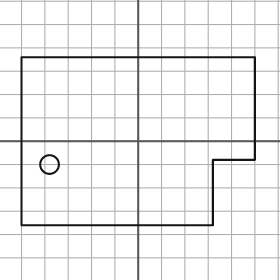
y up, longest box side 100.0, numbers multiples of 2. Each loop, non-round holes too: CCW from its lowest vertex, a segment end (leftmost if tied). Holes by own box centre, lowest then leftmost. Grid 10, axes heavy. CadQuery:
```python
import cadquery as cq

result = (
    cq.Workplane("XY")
    .moveTo(-50.0, -36.0)
    .lineTo(32.0, -36.0)
    .lineTo(32.0, -8.0)
    .lineTo(50.0, -8.0)
    .lineTo(50.0, 36.0)
    .lineTo(-50.0, 36.0)
    .close()
    .moveTo(-38.0, -10.0)
    .circle(4.0)
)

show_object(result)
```